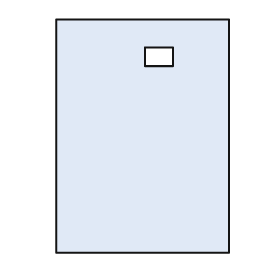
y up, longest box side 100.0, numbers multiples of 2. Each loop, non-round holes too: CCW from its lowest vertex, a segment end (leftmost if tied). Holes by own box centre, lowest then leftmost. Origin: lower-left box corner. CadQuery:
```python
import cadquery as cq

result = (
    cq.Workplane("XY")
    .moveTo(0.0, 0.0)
    .lineTo(74.0, 0.0)
    .lineTo(74.0, 100.0)
    .lineTo(0.0, 100.0)
    .close()
    .moveTo(38.0, 80.0)
    .lineTo(50.0, 80.0)
    .lineTo(50.0, 88.0)
    .lineTo(38.0, 88.0)
    .close()
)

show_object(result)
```